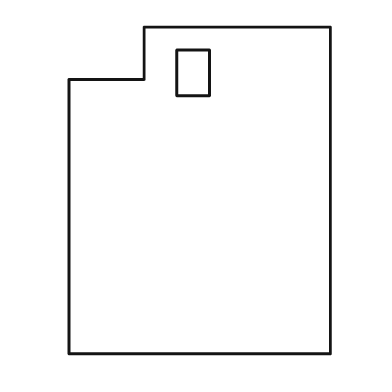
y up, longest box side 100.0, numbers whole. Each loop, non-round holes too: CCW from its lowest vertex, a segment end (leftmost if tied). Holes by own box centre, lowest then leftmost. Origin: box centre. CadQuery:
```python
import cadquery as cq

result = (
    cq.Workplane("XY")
    .moveTo(-40.0, -50.0)
    .lineTo(40.0, -50.0)
    .lineTo(40.0, 50.0)
    .lineTo(-17.0, 50.0)
    .lineTo(-17.0, 34.0)
    .lineTo(-40.0, 34.0)
    .close()
    .moveTo(-7.0, 29.0)
    .lineTo(3.0, 29.0)
    .lineTo(3.0, 43.0)
    .lineTo(-7.0, 43.0)
    .close()
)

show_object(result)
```